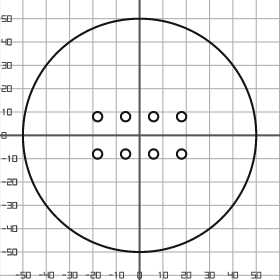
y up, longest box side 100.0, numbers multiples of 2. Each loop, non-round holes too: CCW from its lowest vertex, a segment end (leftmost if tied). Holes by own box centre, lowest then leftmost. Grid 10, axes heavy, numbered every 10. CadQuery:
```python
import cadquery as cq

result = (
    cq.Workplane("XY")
    .moveTo(0.0, 0.0)
    .circle(50.0)
    .moveTo(-18.0, -8.0)
    .circle(2.0)
    .moveTo(-6.0, -8.0)
    .circle(2.0)
    .moveTo(6.0, -8.0)
    .circle(2.0)
    .moveTo(18.0, -8.0)
    .circle(2.0)
    .moveTo(-18.0, 8.0)
    .circle(2.0)
    .moveTo(-6.0, 8.0)
    .circle(2.0)
    .moveTo(6.0, 8.0)
    .circle(2.0)
    .moveTo(18.0, 8.0)
    .circle(2.0)
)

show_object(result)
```